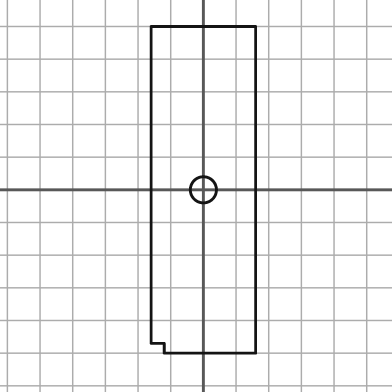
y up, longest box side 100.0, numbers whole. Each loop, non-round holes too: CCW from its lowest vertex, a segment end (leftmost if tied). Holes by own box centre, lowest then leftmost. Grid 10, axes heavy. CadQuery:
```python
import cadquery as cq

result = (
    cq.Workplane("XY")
    .moveTo(-12.0, -50.0)
    .lineTo(16.0, -50.0)
    .lineTo(16.0, 50.0)
    .lineTo(-16.0, 50.0)
    .lineTo(-16.0, -47.0)
    .lineTo(-12.0, -47.0)
    .close()
    .moveTo(0.0, 0.0)
    .circle(4.0)
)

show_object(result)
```